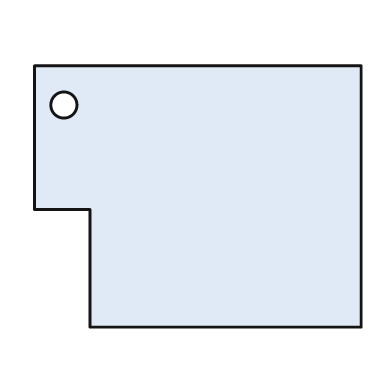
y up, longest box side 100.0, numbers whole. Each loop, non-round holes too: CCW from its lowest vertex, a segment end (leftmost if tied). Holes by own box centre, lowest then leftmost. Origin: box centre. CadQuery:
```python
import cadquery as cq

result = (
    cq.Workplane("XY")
    .moveTo(-33.0, -40.0)
    .lineTo(50.0, -40.0)
    .lineTo(50.0, 40.0)
    .lineTo(-50.0, 40.0)
    .lineTo(-50.0, -4.0)
    .lineTo(-33.0, -4.0)
    .close()
    .moveTo(-41.0, 28.0)
    .circle(4.0)
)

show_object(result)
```